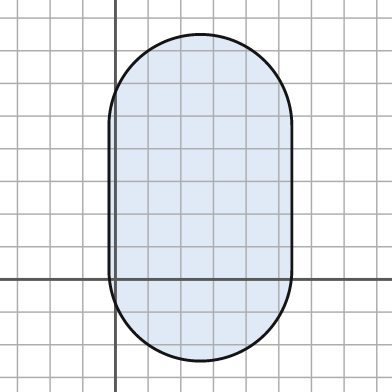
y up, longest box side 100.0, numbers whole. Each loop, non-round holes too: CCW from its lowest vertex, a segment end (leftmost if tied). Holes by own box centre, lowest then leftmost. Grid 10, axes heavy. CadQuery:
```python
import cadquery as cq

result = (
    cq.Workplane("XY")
    .moveTo(-2.0, 3.0)
    .threePointArc((26.0, -25.0), (54.0, 3.0))
    .lineTo(54.0, 47.0)
    .threePointArc((26.0, 75.0), (-2.0, 47.0))
    .close()
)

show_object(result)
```